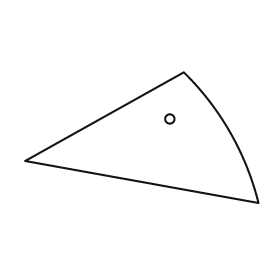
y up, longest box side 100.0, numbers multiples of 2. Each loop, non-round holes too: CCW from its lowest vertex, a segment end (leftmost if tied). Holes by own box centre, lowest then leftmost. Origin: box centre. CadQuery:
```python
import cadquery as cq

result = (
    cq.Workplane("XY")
    .moveTo(50.0, -28.0)
    .threePointArc((38.0, 2.0), (18.0, 28.0))
    .lineTo(-50.0, -10.0)
    .close()
    .moveTo(12.0, 8.0)
    .circle(2.0)
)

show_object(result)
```